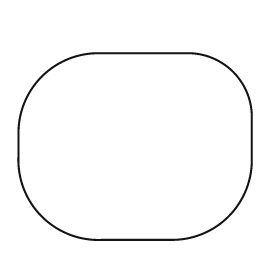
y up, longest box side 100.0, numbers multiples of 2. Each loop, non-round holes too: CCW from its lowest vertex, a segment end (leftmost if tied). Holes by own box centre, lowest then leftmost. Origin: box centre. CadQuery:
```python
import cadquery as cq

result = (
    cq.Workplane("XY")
    .moveTo(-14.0, -40.0)
    .lineTo(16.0, -40.0)
    .threePointArc((40.0, -30.0), (50.0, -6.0))
    .lineTo(50.0, 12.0)
    .threePointArc((42.0, 32.0), (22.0, 40.0))
    .lineTo(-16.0, 40.0)
    .threePointArc((-40.0, 30.0), (-50.0, 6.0))
    .lineTo(-50.0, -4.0)
    .threePointArc((-40.0, -30.0), (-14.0, -40.0))
    .close()
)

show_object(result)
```